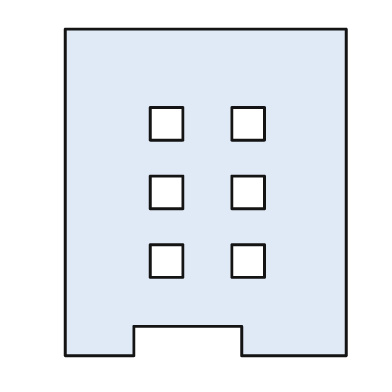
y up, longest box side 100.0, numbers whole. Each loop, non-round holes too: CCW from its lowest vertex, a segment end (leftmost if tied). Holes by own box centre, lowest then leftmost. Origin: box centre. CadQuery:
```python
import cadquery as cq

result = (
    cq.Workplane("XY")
    .moveTo(-43.0, -50.0)
    .lineTo(-22.0, -50.0)
    .lineTo(-22.0, -41.0)
    .lineTo(11.0, -41.0)
    .lineTo(11.0, -50.0)
    .lineTo(43.0, -50.0)
    .lineTo(43.0, 50.0)
    .lineTo(-43.0, 50.0)
    .close()
    .moveTo(-17.0, -26.0)
    .lineTo(-7.0, -26.0)
    .lineTo(-7.0, -16.0)
    .lineTo(-17.0, -16.0)
    .close()
    .moveTo(8.0, -26.0)
    .lineTo(18.0, -26.0)
    .lineTo(18.0, -16.0)
    .lineTo(8.0, -16.0)
    .close()
    .moveTo(-17.0, -5.0)
    .lineTo(-7.0, -5.0)
    .lineTo(-7.0, 5.0)
    .lineTo(-17.0, 5.0)
    .close()
    .moveTo(8.0, -5.0)
    .lineTo(18.0, -5.0)
    .lineTo(18.0, 5.0)
    .lineTo(8.0, 5.0)
    .close()
    .moveTo(-17.0, 16.0)
    .lineTo(-7.0, 16.0)
    .lineTo(-7.0, 26.0)
    .lineTo(-17.0, 26.0)
    .close()
    .moveTo(8.0, 16.0)
    .lineTo(18.0, 16.0)
    .lineTo(18.0, 26.0)
    .lineTo(8.0, 26.0)
    .close()
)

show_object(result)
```